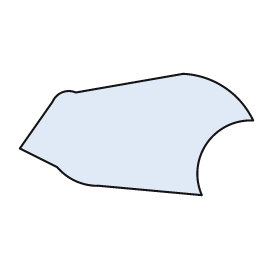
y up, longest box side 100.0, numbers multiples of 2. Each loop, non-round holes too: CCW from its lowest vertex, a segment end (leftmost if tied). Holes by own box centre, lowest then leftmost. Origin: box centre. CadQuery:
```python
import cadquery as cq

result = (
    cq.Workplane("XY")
    .moveTo(28.0, -26.0)
    .threePointArc((30.0, -4.0), (50.0, 6.0))
    .threePointArc((38.0, 20.0), (20.0, 26.0))
    .lineTo(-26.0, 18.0)
    .threePointArc((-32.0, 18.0), (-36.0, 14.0))
    .lineTo(-50.0, -6.0)
    .lineTo(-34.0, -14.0)
    .threePointArc((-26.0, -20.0), (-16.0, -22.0))
    .close()
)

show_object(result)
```